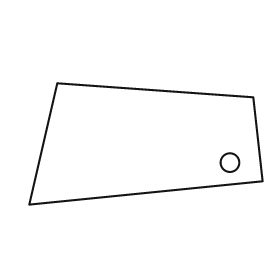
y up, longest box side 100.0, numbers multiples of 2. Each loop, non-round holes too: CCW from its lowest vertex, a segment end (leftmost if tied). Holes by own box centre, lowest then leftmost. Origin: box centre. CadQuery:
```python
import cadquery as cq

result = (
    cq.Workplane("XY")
    .moveTo(-50.0, -26.0)
    .lineTo(50.0, -16.0)
    .lineTo(46.0, 20.0)
    .lineTo(-38.0, 26.0)
    .close()
    .moveTo(36.0, -8.0)
    .circle(4.0)
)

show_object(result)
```